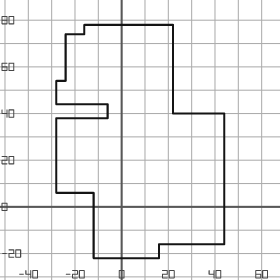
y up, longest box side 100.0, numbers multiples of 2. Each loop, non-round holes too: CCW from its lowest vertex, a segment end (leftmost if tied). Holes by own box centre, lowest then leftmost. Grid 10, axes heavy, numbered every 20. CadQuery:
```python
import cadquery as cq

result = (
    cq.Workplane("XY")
    .moveTo(-12.0, -22.0)
    .lineTo(16.0, -22.0)
    .lineTo(16.0, -16.0)
    .lineTo(44.0, -16.0)
    .lineTo(44.0, 40.0)
    .lineTo(22.0, 40.0)
    .lineTo(22.0, 78.0)
    .lineTo(-16.0, 78.0)
    .lineTo(-16.0, 74.0)
    .lineTo(-24.0, 74.0)
    .lineTo(-24.0, 54.0)
    .lineTo(-28.0, 54.0)
    .lineTo(-28.0, 44.0)
    .lineTo(-6.0, 44.0)
    .lineTo(-6.0, 38.0)
    .lineTo(-28.0, 38.0)
    .lineTo(-28.0, 6.0)
    .lineTo(-12.0, 6.0)
    .close()
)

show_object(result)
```